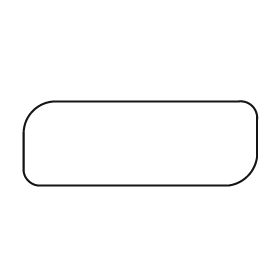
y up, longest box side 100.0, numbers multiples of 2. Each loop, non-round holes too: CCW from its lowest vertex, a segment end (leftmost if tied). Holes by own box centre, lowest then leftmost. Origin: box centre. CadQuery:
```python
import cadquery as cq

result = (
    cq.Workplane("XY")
    .moveTo(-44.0, -18.0)
    .lineTo(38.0, -18.0)
    .threePointArc((46.0, -14.0), (50.0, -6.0))
    .lineTo(50.0, 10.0)
    .threePointArc((48.0, 16.0), (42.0, 18.0))
    .lineTo(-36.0, 18.0)
    .threePointArc((-46.0, 14.0), (-50.0, 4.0))
    .lineTo(-50.0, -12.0)
    .threePointArc((-48.0, -16.0), (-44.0, -18.0))
    .close()
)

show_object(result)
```